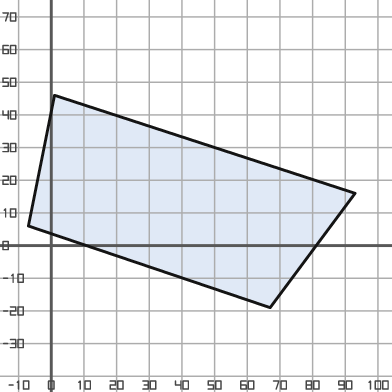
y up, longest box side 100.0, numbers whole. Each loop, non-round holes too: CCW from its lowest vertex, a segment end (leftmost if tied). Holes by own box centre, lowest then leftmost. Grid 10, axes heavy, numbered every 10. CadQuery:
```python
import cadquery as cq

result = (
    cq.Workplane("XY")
    .moveTo(67.0, -19.0)
    .lineTo(93.0, 16.0)
    .lineTo(1.0, 46.0)
    .lineTo(-7.0, 6.0)
    .close()
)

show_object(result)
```